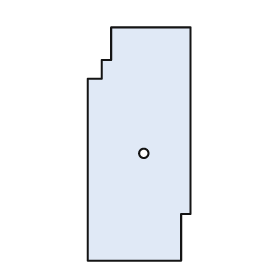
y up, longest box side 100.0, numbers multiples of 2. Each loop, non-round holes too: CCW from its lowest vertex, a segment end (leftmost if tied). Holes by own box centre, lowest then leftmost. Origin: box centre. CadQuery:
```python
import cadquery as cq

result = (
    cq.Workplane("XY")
    .moveTo(-22.0, -50.0)
    .lineTo(18.0, -50.0)
    .lineTo(18.0, -30.0)
    .lineTo(22.0, -30.0)
    .lineTo(22.0, 50.0)
    .lineTo(-12.0, 50.0)
    .lineTo(-12.0, 36.0)
    .lineTo(-16.0, 36.0)
    .lineTo(-16.0, 28.0)
    .lineTo(-22.0, 28.0)
    .close()
    .moveTo(2.0, -4.0)
    .circle(2.0)
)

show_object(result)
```